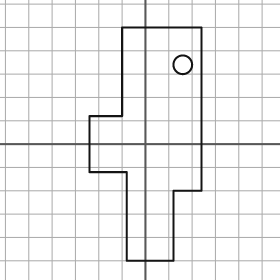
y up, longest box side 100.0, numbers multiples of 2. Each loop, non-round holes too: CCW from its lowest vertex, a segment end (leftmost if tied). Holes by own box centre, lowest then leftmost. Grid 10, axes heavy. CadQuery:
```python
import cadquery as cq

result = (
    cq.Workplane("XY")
    .moveTo(-8.0, -50.0)
    .lineTo(12.0, -50.0)
    .lineTo(12.0, -20.0)
    .lineTo(24.0, -20.0)
    .lineTo(24.0, 50.0)
    .lineTo(-10.0, 50.0)
    .lineTo(-10.0, 12.0)
    .lineTo(-24.0, 12.0)
    .lineTo(-24.0, -12.0)
    .lineTo(-8.0, -12.0)
    .close()
    .moveTo(16.0, 34.0)
    .circle(4.0)
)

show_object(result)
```